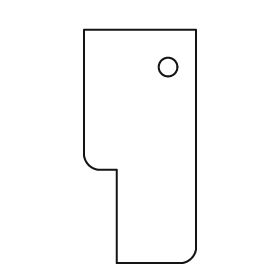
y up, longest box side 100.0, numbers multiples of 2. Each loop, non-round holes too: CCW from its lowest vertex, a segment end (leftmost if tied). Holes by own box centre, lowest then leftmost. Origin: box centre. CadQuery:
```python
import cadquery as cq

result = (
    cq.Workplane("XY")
    .moveTo(-10.0, -50.0)
    .lineTo(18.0, -50.0)
    .threePointArc((22.0, -48.0), (24.0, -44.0))
    .lineTo(24.0, 50.0)
    .lineTo(-24.0, 50.0)
    .lineTo(-24.0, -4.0)
    .threePointArc((-22.0, -8.0), (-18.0, -10.0))
    .lineTo(-10.0, -10.0)
    .close()
    .moveTo(12.0, 34.0)
    .circle(4.0)
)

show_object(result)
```